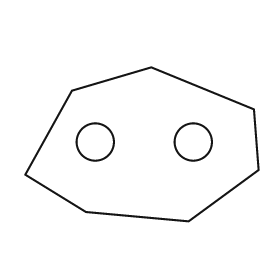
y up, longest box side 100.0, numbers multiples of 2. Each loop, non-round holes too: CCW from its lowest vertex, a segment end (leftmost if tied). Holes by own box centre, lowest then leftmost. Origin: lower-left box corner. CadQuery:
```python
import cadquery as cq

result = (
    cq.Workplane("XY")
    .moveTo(70.0, 0.0)
    .lineTo(100.0, 22.0)
    .lineTo(98.0, 48.0)
    .lineTo(54.0, 66.0)
    .lineTo(20.0, 56.0)
    .lineTo(0.0, 20.0)
    .lineTo(26.0, 4.0)
    .close()
    .moveTo(30.0, 34.0)
    .circle(8.0)
    .moveTo(72.0, 34.0)
    .circle(8.0)
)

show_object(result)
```